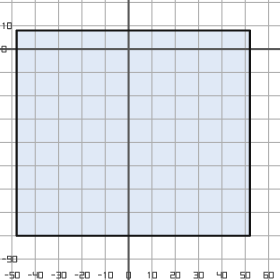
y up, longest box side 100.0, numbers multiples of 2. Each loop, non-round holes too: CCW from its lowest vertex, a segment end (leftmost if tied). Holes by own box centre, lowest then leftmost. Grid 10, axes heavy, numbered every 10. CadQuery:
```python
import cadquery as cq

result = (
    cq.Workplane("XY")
    .moveTo(-48.0, -80.0)
    .lineTo(52.0, -80.0)
    .lineTo(52.0, 8.0)
    .lineTo(-48.0, 8.0)
    .close()
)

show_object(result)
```